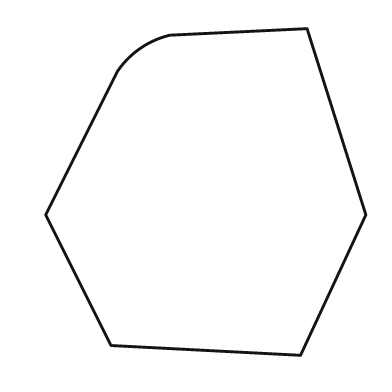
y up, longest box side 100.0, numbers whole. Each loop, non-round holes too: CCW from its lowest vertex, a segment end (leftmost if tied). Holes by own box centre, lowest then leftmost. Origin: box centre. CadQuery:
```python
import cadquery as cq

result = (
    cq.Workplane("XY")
    .moveTo(29.0, -50.0)
    .lineTo(49.0, -7.0)
    .lineTo(31.0, 50.0)
    .lineTo(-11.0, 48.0)
    .threePointArc((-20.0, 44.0), (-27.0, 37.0))
    .lineTo(-49.0, -7.0)
    .lineTo(-29.0, -47.0)
    .close()
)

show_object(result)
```